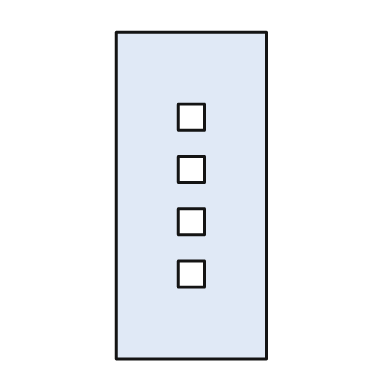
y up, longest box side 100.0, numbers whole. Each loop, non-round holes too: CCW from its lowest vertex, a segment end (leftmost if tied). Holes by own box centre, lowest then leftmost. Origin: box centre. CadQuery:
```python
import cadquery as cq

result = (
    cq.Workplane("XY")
    .moveTo(-23.0, -50.0)
    .lineTo(23.0, -50.0)
    .lineTo(23.0, 50.0)
    .lineTo(-23.0, 50.0)
    .close()
    .moveTo(-4.0, -28.0)
    .lineTo(4.0, -28.0)
    .lineTo(4.0, -20.0)
    .lineTo(-4.0, -20.0)
    .close()
    .moveTo(-4.0, -12.0)
    .lineTo(4.0, -12.0)
    .lineTo(4.0, -4.0)
    .lineTo(-4.0, -4.0)
    .close()
    .moveTo(-4.0, 4.0)
    .lineTo(4.0, 4.0)
    .lineTo(4.0, 12.0)
    .lineTo(-4.0, 12.0)
    .close()
    .moveTo(-4.0, 20.0)
    .lineTo(4.0, 20.0)
    .lineTo(4.0, 28.0)
    .lineTo(-4.0, 28.0)
    .close()
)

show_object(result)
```